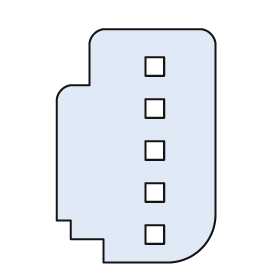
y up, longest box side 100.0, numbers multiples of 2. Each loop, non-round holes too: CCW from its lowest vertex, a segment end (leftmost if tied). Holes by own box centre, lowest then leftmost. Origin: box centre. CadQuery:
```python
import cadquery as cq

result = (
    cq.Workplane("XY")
    .moveTo(-14.0, -50.0)
    .lineTo(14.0, -50.0)
    .threePointArc((28.0, -44.0), (34.0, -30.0))
    .lineTo(34.0, 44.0)
    .threePointArc((32.0, 48.0), (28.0, 50.0))
    .lineTo(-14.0, 50.0)
    .threePointArc((-18.0, 48.0), (-20.0, 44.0))
    .lineTo(-20.0, 26.0)
    .lineTo(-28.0, 26.0)
    .threePointArc((-32.0, 24.0), (-34.0, 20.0))
    .lineTo(-34.0, -32.0)
    .lineTo(-28.0, -32.0)
    .lineTo(-28.0, -40.0)
    .lineTo(-14.0, -40.0)
    .close()
    .moveTo(4.0, -42.0)
    .lineTo(12.0, -42.0)
    .lineTo(12.0, -34.0)
    .lineTo(4.0, -34.0)
    .close()
    .moveTo(4.0, -24.0)
    .lineTo(12.0, -24.0)
    .lineTo(12.0, -16.0)
    .lineTo(4.0, -16.0)
    .close()
    .moveTo(4.0, -6.0)
    .lineTo(12.0, -6.0)
    .lineTo(12.0, 2.0)
    .lineTo(4.0, 2.0)
    .close()
    .moveTo(4.0, 12.0)
    .lineTo(12.0, 12.0)
    .lineTo(12.0, 20.0)
    .lineTo(4.0, 20.0)
    .close()
    .moveTo(4.0, 30.0)
    .lineTo(12.0, 30.0)
    .lineTo(12.0, 38.0)
    .lineTo(4.0, 38.0)
    .close()
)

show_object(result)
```